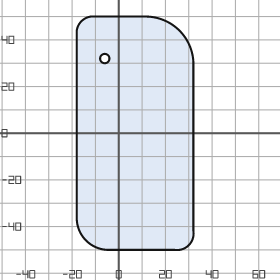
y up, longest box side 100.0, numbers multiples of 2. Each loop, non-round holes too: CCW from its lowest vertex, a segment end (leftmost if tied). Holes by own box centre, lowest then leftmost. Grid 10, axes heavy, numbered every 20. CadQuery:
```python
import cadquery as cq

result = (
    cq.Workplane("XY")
    .moveTo(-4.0, -50.0)
    .lineTo(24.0, -50.0)
    .threePointArc((30.0, -48.0), (32.0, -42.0))
    .lineTo(32.0, 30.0)
    .threePointArc((26.0, 44.0), (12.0, 50.0))
    .lineTo(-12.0, 50.0)
    .threePointArc((-16.0, 48.0), (-18.0, 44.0))
    .lineTo(-18.0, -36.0)
    .threePointArc((-14.0, -46.0), (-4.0, -50.0))
    .close()
    .moveTo(-6.0, 32.0)
    .circle(2.0)
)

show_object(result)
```